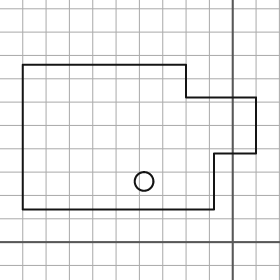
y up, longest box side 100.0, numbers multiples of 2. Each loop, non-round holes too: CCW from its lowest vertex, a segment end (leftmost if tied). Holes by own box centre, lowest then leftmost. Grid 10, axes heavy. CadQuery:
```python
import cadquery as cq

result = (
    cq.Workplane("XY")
    .moveTo(-90.0, 14.0)
    .lineTo(-8.0, 14.0)
    .lineTo(-8.0, 38.0)
    .lineTo(10.0, 38.0)
    .lineTo(10.0, 62.0)
    .lineTo(-20.0, 62.0)
    .lineTo(-20.0, 76.0)
    .lineTo(-90.0, 76.0)
    .close()
    .moveTo(-38.0, 26.0)
    .circle(4.0)
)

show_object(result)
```